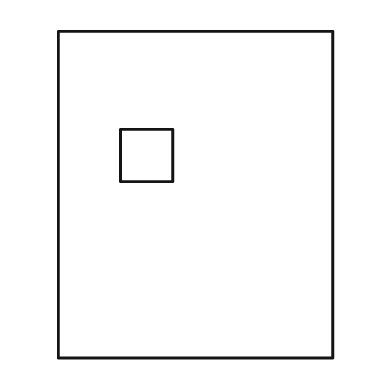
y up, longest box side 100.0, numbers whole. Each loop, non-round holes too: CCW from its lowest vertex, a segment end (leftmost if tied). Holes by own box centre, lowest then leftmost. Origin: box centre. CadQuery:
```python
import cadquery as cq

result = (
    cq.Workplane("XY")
    .moveTo(-42.0, -50.0)
    .lineTo(42.0, -50.0)
    .lineTo(42.0, 50.0)
    .lineTo(-42.0, 50.0)
    .close()
    .moveTo(-23.0, 4.0)
    .lineTo(-7.0, 4.0)
    .lineTo(-7.0, 20.0)
    .lineTo(-23.0, 20.0)
    .close()
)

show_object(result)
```